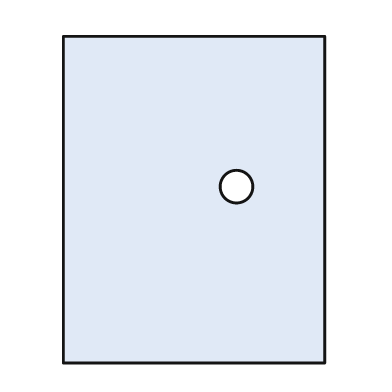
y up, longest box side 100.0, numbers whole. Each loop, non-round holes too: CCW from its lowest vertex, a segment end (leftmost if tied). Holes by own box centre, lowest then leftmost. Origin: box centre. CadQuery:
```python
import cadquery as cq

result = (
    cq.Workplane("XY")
    .moveTo(-40.0, -50.0)
    .lineTo(40.0, -50.0)
    .lineTo(40.0, 50.0)
    .lineTo(-40.0, 50.0)
    .close()
    .moveTo(13.0, 4.0)
    .circle(5.0)
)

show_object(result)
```